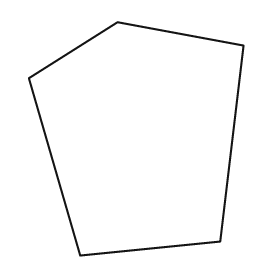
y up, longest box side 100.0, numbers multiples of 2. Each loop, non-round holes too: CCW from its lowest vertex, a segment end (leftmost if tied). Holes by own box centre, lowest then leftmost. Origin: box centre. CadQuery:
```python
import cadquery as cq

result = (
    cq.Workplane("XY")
    .moveTo(-24.0, -50.0)
    .lineTo(36.0, -44.0)
    .lineTo(46.0, 40.0)
    .lineTo(-8.0, 50.0)
    .lineTo(-46.0, 26.0)
    .close()
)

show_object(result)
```